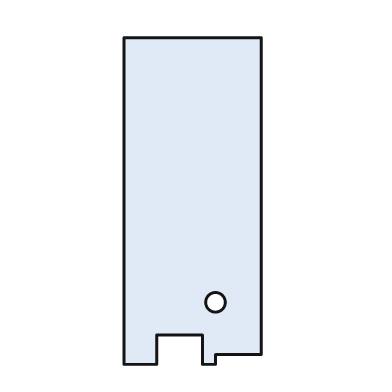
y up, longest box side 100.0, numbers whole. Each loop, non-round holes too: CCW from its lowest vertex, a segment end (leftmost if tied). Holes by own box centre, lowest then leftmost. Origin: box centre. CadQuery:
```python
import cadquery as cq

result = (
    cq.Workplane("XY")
    .moveTo(-21.0, -50.0)
    .lineTo(-11.0, -50.0)
    .lineTo(-11.0, -41.0)
    .lineTo(3.0, -41.0)
    .lineTo(3.0, -50.0)
    .lineTo(7.0, -50.0)
    .lineTo(7.0, -47.0)
    .lineTo(21.0, -47.0)
    .lineTo(21.0, 50.0)
    .lineTo(-21.0, 50.0)
    .close()
    .moveTo(7.0, -31.0)
    .circle(3.0)
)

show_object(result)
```